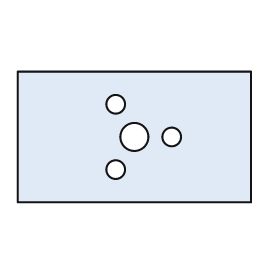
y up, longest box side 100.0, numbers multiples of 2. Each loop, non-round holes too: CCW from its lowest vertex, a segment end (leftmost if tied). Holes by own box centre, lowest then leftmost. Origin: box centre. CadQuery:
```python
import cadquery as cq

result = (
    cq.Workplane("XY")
    .moveTo(-50.0, -28.0)
    .lineTo(50.0, -28.0)
    .lineTo(50.0, 28.0)
    .lineTo(-50.0, 28.0)
    .close()
    .moveTo(-8.0, -14.0)
    .circle(4.0)
    .moveTo(0.0, 0.0)
    .circle(6.0)
    .moveTo(16.0, 0.0)
    .circle(4.0)
    .moveTo(-8.0, 14.0)
    .circle(4.0)
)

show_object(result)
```